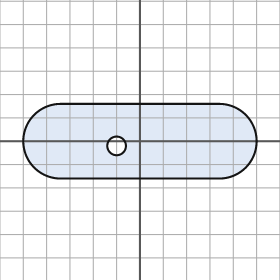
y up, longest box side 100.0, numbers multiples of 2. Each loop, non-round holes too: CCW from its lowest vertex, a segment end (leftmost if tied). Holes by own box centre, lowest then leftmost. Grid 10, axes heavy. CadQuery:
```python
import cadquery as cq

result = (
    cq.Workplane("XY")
    .moveTo(-34.0, -16.0)
    .lineTo(34.0, -16.0)
    .threePointArc((50.0, 0.0), (34.0, 16.0))
    .lineTo(-34.0, 16.0)
    .threePointArc((-50.0, 0.0), (-34.0, -16.0))
    .close()
    .moveTo(-10.0, -2.0)
    .circle(4.0)
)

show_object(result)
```